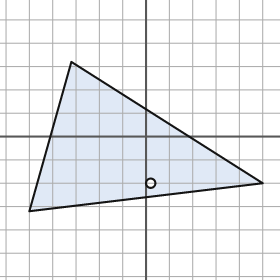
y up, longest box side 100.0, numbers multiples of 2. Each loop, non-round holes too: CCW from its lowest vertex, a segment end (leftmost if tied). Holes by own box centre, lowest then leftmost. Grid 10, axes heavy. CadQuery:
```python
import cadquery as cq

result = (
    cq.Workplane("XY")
    .moveTo(-50.0, -32.0)
    .lineTo(50.0, -20.0)
    .lineTo(-32.0, 32.0)
    .close()
    .moveTo(2.0, -20.0)
    .circle(2.0)
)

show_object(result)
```